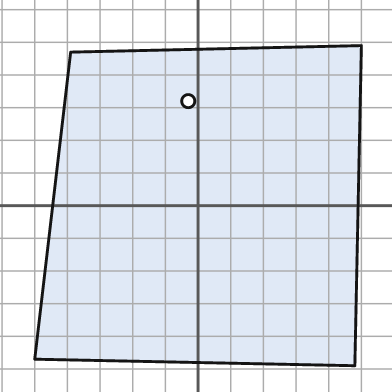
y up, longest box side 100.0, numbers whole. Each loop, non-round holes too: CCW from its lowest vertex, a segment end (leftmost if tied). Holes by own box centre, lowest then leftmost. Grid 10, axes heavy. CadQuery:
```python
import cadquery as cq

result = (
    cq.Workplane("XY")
    .moveTo(48.0, -49.0)
    .lineTo(50.0, 49.0)
    .lineTo(-39.0, 47.0)
    .lineTo(-50.0, -47.0)
    .close()
    .moveTo(-3.0, 32.0)
    .circle(2.0)
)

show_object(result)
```